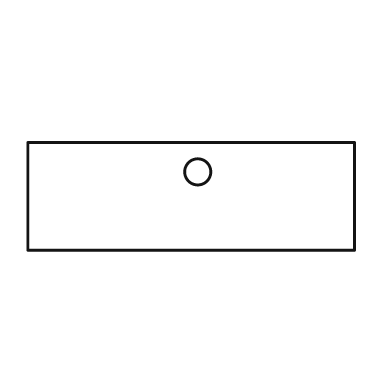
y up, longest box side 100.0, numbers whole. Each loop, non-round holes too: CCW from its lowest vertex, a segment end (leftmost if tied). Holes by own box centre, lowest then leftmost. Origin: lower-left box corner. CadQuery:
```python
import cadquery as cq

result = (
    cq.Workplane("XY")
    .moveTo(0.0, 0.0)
    .lineTo(100.0, 0.0)
    .lineTo(100.0, 33.0)
    .lineTo(0.0, 33.0)
    .close()
    .moveTo(52.0, 24.0)
    .circle(4.0)
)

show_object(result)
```